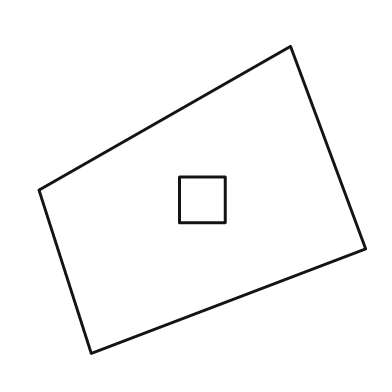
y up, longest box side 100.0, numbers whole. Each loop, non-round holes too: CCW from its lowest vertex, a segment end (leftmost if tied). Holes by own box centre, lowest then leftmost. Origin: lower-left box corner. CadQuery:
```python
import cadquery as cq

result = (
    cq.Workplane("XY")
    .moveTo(16.0, 0.0)
    .lineTo(100.0, 32.0)
    .lineTo(77.0, 94.0)
    .lineTo(0.0, 50.0)
    .close()
    .moveTo(43.0, 40.0)
    .lineTo(57.0, 40.0)
    .lineTo(57.0, 54.0)
    .lineTo(43.0, 54.0)
    .close()
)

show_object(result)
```